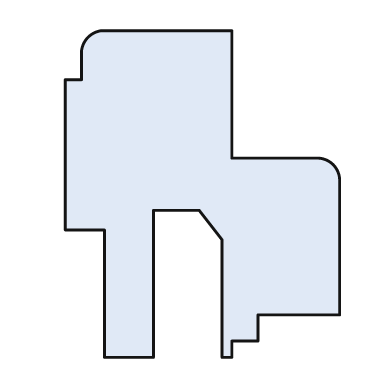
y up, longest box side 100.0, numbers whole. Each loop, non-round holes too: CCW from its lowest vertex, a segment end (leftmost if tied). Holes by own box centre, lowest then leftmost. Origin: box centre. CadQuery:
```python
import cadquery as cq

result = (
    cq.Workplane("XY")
    .moveTo(-30.0, -50.0)
    .lineTo(-15.0, -50.0)
    .lineTo(-15.0, -5.0)
    .lineTo(-1.0, -5.0)
    .lineTo(6.0, -14.0)
    .lineTo(6.0, -50.0)
    .lineTo(9.0, -50.0)
    .lineTo(9.0, -45.0)
    .lineTo(17.0, -45.0)
    .lineTo(17.0, -37.0)
    .lineTo(42.0, -37.0)
    .lineTo(42.0, 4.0)
    .threePointArc((40.0, 9.0), (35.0, 11.0))
    .lineTo(9.0, 11.0)
    .lineTo(9.0, 50.0)
    .lineTo(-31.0, 50.0)
    .threePointArc((-35.0, 48.0), (-37.0, 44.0))
    .lineTo(-37.0, 35.0)
    .lineTo(-42.0, 35.0)
    .lineTo(-42.0, -11.0)
    .lineTo(-30.0, -11.0)
    .close()
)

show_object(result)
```